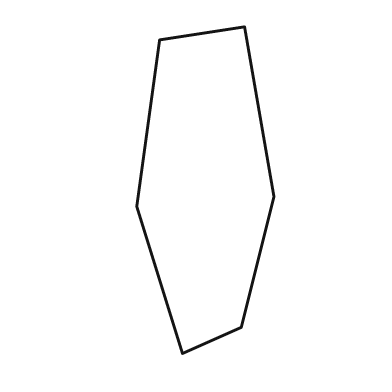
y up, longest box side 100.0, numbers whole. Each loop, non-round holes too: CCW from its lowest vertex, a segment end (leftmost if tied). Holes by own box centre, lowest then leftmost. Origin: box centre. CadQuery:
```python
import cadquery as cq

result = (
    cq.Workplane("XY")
    .moveTo(-7.0, -50.0)
    .lineTo(11.0, -42.0)
    .lineTo(21.0, -2.0)
    .lineTo(12.0, 50.0)
    .lineTo(-14.0, 46.0)
    .lineTo(-21.0, -5.0)
    .close()
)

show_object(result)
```